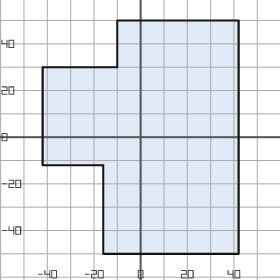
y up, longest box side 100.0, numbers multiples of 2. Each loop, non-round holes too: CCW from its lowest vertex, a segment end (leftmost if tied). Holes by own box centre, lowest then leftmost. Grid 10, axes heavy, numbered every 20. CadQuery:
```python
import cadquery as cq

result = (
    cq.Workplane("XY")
    .moveTo(-16.0, -50.0)
    .lineTo(42.0, -50.0)
    .lineTo(42.0, 50.0)
    .lineTo(-10.0, 50.0)
    .lineTo(-10.0, 30.0)
    .lineTo(-42.0, 30.0)
    .lineTo(-42.0, -12.0)
    .lineTo(-16.0, -12.0)
    .close()
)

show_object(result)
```